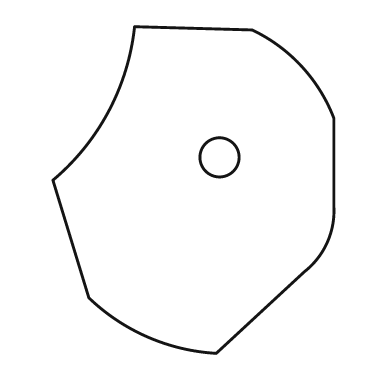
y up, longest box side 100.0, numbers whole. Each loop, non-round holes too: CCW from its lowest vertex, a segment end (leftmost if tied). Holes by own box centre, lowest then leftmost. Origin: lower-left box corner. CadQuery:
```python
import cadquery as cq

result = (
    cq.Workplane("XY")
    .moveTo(50.0, 0.0)
    .lineTo(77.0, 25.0)
    .threePointArc((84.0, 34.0), (86.0, 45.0))
    .lineTo(86.0, 72.0)
    .threePointArc((76.0, 88.0), (61.0, 99.0))
    .lineTo(25.0, 100.0)
    .threePointArc((17.0, 74.0), (0.0, 53.0))
    .lineTo(11.0, 17.0)
    .threePointArc((29.0, 5.0), (50.0, 0.0))
    .close()
    .moveTo(51.0, 60.0)
    .circle(6.0)
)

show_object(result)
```